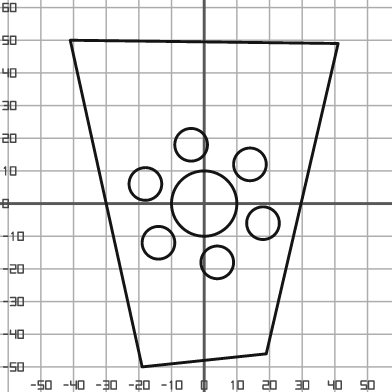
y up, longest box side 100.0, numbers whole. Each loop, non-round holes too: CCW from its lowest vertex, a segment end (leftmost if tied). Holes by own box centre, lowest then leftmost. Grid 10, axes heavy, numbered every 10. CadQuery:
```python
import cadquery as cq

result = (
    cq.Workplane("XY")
    .moveTo(-19.0, -50.0)
    .lineTo(19.0, -46.0)
    .lineTo(41.0, 49.0)
    .lineTo(-41.0, 50.0)
    .close()
    .moveTo(4.0, -18.0)
    .circle(5.0)
    .moveTo(-14.0, -12.0)
    .circle(5.0)
    .moveTo(18.0, -6.0)
    .circle(5.0)
    .moveTo(0.0, 0.0)
    .circle(10.0)
    .moveTo(-18.0, 6.0)
    .circle(5.0)
    .moveTo(14.0, 12.0)
    .circle(5.0)
    .moveTo(-4.0, 18.0)
    .circle(5.0)
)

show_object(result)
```